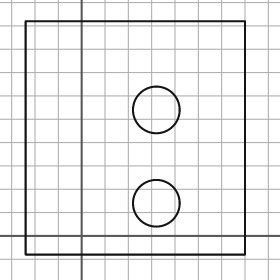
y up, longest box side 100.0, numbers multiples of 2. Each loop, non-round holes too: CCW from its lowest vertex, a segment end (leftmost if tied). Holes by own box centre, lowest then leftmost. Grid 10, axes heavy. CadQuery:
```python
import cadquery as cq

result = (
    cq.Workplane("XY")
    .moveTo(-24.0, -8.0)
    .lineTo(70.0, -8.0)
    .lineTo(70.0, 92.0)
    .lineTo(-24.0, 92.0)
    .close()
    .moveTo(32.0, 14.0)
    .circle(10.0)
    .moveTo(32.0, 54.0)
    .circle(10.0)
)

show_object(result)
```